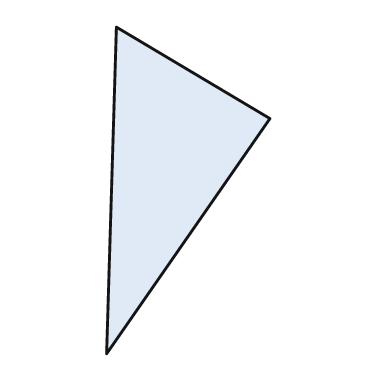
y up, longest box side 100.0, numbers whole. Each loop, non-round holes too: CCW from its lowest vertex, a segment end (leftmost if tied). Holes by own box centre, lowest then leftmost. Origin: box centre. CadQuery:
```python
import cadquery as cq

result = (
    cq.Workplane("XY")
    .moveTo(-25.0, -50.0)
    .lineTo(25.0, 22.0)
    .lineTo(-22.0, 50.0)
    .close()
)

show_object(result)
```